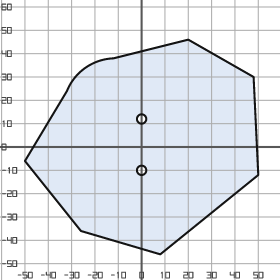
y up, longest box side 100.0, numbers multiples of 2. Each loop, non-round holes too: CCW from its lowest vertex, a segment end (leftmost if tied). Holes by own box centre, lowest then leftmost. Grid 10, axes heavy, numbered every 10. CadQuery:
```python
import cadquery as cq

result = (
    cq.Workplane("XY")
    .moveTo(8.0, -46.0)
    .lineTo(50.0, -12.0)
    .lineTo(48.0, 30.0)
    .lineTo(20.0, 46.0)
    .lineTo(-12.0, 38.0)
    .threePointArc((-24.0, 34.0), (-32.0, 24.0))
    .lineTo(-50.0, -6.0)
    .lineTo(-26.0, -36.0)
    .close()
    .moveTo(0.0, -10.0)
    .circle(2.0)
    .moveTo(0.0, 12.0)
    .circle(2.0)
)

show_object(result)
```